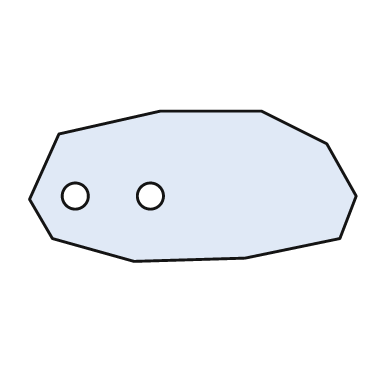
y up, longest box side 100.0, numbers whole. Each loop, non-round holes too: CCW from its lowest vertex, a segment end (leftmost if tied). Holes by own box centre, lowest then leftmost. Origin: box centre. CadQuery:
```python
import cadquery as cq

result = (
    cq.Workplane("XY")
    .moveTo(-18.0, -23.0)
    .lineTo(16.0, -22.0)
    .lineTo(45.0, -16.0)
    .lineTo(50.0, -3.0)
    .lineTo(41.0, 13.0)
    .lineTo(21.0, 23.0)
    .lineTo(-10.0, 23.0)
    .lineTo(-41.0, 16.0)
    .lineTo(-50.0, -4.0)
    .lineTo(-43.0, -16.0)
    .close()
    .moveTo(-36.0, -3.0)
    .circle(4.0)
    .moveTo(-13.0, -3.0)
    .circle(4.0)
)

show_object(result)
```